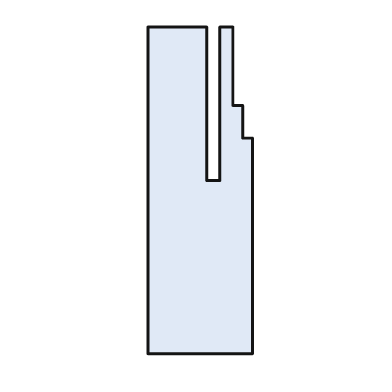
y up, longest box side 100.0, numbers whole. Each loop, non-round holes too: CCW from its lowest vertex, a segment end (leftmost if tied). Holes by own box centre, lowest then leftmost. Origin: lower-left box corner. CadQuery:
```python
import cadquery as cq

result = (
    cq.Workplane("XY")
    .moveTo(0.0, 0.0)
    .lineTo(32.0, 0.0)
    .lineTo(32.0, 66.0)
    .lineTo(29.0, 66.0)
    .lineTo(29.0, 76.0)
    .lineTo(26.0, 76.0)
    .lineTo(26.0, 100.0)
    .lineTo(22.0, 100.0)
    .lineTo(22.0, 53.0)
    .lineTo(18.0, 53.0)
    .lineTo(18.0, 100.0)
    .lineTo(0.0, 100.0)
    .close()
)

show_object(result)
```